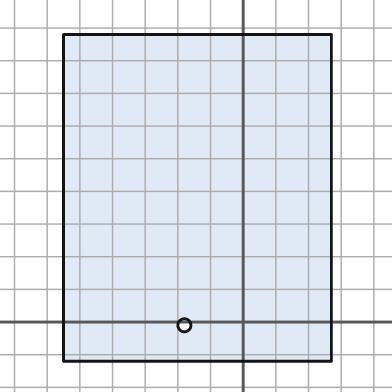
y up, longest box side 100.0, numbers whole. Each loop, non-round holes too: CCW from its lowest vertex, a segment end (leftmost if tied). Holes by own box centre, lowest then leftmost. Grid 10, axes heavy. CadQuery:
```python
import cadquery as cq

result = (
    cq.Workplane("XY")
    .moveTo(-55.0, -12.0)
    .lineTo(27.0, -12.0)
    .lineTo(27.0, 88.0)
    .lineTo(-55.0, 88.0)
    .close()
    .moveTo(-18.0, -1.0)
    .circle(2.0)
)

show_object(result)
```